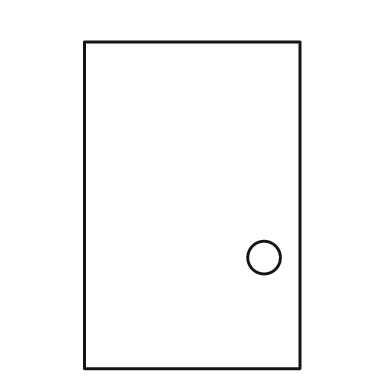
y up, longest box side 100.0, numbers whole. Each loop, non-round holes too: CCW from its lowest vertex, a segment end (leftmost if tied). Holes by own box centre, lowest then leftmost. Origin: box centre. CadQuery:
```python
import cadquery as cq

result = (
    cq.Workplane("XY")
    .moveTo(-33.0, -50.0)
    .lineTo(33.0, -50.0)
    .lineTo(33.0, 50.0)
    .lineTo(-33.0, 50.0)
    .close()
    .moveTo(22.0, -16.0)
    .circle(5.0)
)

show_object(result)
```